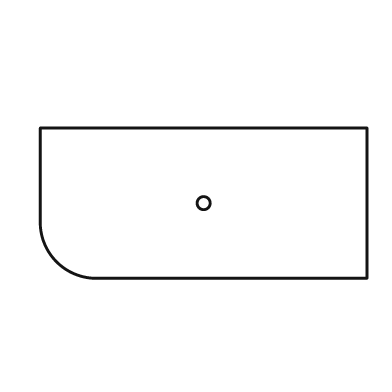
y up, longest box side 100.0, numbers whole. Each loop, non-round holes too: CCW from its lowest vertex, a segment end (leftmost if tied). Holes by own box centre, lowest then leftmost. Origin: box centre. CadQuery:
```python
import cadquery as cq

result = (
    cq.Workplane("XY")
    .moveTo(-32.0, -23.0)
    .lineTo(50.0, -23.0)
    .lineTo(50.0, 23.0)
    .lineTo(-50.0, 23.0)
    .lineTo(-50.0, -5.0)
    .threePointArc((-45.0, -18.0), (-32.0, -23.0))
    .close()
    .moveTo(0.0, 0.0)
    .circle(2.0)
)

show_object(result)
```